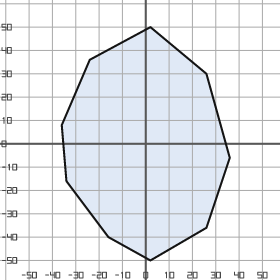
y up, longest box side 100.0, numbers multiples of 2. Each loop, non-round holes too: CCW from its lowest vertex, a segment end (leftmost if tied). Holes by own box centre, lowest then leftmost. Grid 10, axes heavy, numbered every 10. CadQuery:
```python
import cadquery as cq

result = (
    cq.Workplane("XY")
    .moveTo(2.0, -50.0)
    .lineTo(26.0, -36.0)
    .lineTo(36.0, -6.0)
    .lineTo(26.0, 30.0)
    .lineTo(2.0, 50.0)
    .lineTo(-24.0, 36.0)
    .lineTo(-36.0, 8.0)
    .lineTo(-34.0, -16.0)
    .lineTo(-16.0, -40.0)
    .close()
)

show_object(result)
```